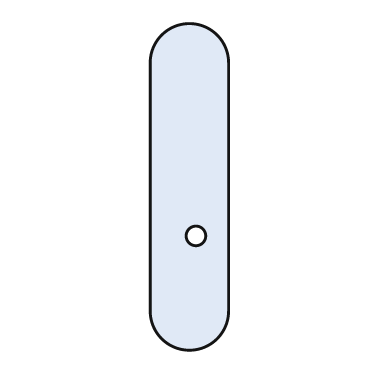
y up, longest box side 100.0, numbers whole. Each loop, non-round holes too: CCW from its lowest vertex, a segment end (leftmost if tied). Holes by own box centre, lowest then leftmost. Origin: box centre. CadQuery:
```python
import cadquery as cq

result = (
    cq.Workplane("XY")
    .moveTo(-12.0, -38.0)
    .threePointArc((0.0, -50.0), (12.0, -38.0))
    .lineTo(12.0, 38.0)
    .threePointArc((0.0, 50.0), (-12.0, 38.0))
    .close()
    .moveTo(2.0, -15.0)
    .circle(3.0)
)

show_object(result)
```